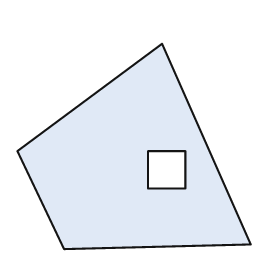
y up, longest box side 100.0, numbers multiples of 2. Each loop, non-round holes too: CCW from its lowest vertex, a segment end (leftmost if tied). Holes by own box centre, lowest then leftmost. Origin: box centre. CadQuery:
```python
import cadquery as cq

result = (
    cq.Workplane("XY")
    .moveTo(-30.0, -44.0)
    .lineTo(50.0, -42.0)
    .lineTo(12.0, 44.0)
    .lineTo(-50.0, -2.0)
    .close()
    .moveTo(6.0, -18.0)
    .lineTo(22.0, -18.0)
    .lineTo(22.0, -2.0)
    .lineTo(6.0, -2.0)
    .close()
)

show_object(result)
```